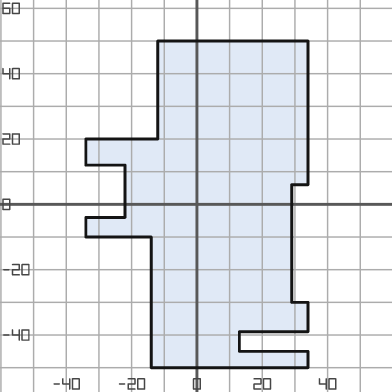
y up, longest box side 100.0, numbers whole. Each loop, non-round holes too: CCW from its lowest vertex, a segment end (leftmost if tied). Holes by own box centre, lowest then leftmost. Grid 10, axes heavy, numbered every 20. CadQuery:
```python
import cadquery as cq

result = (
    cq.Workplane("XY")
    .moveTo(-14.0, -50.0)
    .lineTo(34.0, -50.0)
    .lineTo(34.0, -45.0)
    .lineTo(13.0, -45.0)
    .lineTo(13.0, -39.0)
    .lineTo(34.0, -39.0)
    .lineTo(34.0, -30.0)
    .lineTo(29.0, -30.0)
    .lineTo(29.0, 6.0)
    .lineTo(34.0, 6.0)
    .lineTo(34.0, 50.0)
    .lineTo(-12.0, 50.0)
    .lineTo(-12.0, 20.0)
    .lineTo(-34.0, 20.0)
    .lineTo(-34.0, 12.0)
    .lineTo(-22.0, 12.0)
    .lineTo(-22.0, -4.0)
    .lineTo(-34.0, -4.0)
    .lineTo(-34.0, -10.0)
    .lineTo(-14.0, -10.0)
    .close()
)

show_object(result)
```